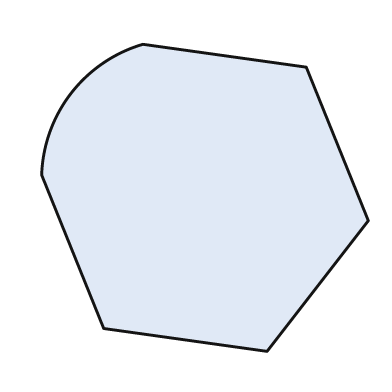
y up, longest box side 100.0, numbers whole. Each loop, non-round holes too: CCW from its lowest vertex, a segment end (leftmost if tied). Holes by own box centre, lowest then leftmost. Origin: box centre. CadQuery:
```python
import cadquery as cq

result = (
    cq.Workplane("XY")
    .moveTo(19.0, -47.0)
    .lineTo(50.0, -7.0)
    .lineTo(31.0, 40.0)
    .lineTo(-19.0, 47.0)
    .threePointArc((-41.0, 32.0), (-50.0, 7.0))
    .lineTo(-31.0, -40.0)
    .close()
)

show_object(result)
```